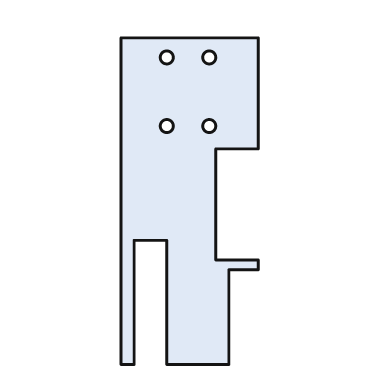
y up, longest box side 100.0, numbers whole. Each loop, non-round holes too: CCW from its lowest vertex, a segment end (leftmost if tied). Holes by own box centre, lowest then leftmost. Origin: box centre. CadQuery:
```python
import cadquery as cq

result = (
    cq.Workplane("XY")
    .moveTo(-21.0, -50.0)
    .lineTo(-17.0, -50.0)
    .lineTo(-17.0, -12.0)
    .lineTo(-7.0, -12.0)
    .lineTo(-7.0, -50.0)
    .lineTo(12.0, -50.0)
    .lineTo(12.0, -21.0)
    .lineTo(21.0, -21.0)
    .lineTo(21.0, -18.0)
    .lineTo(8.0, -18.0)
    .lineTo(8.0, 16.0)
    .lineTo(21.0, 16.0)
    .lineTo(21.0, 50.0)
    .lineTo(-21.0, 50.0)
    .close()
    .moveTo(-7.0, 23.0)
    .circle(2.0)
    .moveTo(6.0, 23.0)
    .circle(2.0)
    .moveTo(-7.0, 44.0)
    .circle(2.0)
    .moveTo(6.0, 44.0)
    .circle(2.0)
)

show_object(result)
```